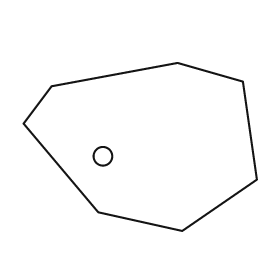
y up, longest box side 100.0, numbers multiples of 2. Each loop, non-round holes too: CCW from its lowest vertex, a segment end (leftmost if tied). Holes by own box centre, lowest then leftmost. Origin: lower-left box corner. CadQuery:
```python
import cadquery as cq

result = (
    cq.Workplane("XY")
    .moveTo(68.0, 0.0)
    .lineTo(100.0, 22.0)
    .lineTo(94.0, 64.0)
    .lineTo(66.0, 72.0)
    .lineTo(12.0, 62.0)
    .lineTo(0.0, 46.0)
    .lineTo(32.0, 8.0)
    .close()
    .moveTo(34.0, 32.0)
    .circle(4.0)
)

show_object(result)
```